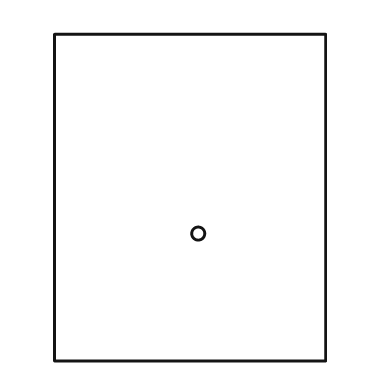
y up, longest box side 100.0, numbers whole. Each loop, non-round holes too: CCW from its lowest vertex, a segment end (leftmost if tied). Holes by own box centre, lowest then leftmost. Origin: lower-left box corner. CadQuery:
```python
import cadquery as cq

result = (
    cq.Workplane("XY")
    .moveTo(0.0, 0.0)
    .lineTo(83.0, 0.0)
    .lineTo(83.0, 100.0)
    .lineTo(0.0, 100.0)
    .close()
    .moveTo(44.0, 39.0)
    .circle(2.0)
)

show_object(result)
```